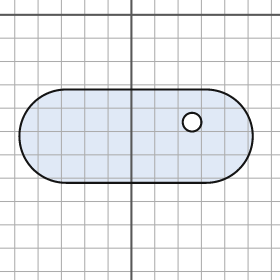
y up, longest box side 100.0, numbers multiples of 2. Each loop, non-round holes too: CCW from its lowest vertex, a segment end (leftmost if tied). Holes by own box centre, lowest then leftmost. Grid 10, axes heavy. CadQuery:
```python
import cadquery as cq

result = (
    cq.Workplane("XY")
    .moveTo(-28.0, -72.0)
    .lineTo(32.0, -72.0)
    .threePointArc((52.0, -52.0), (32.0, -32.0))
    .lineTo(-28.0, -32.0)
    .threePointArc((-48.0, -52.0), (-28.0, -72.0))
    .close()
    .moveTo(26.0, -46.0)
    .circle(4.0)
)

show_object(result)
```